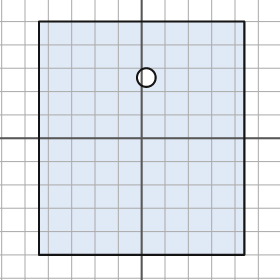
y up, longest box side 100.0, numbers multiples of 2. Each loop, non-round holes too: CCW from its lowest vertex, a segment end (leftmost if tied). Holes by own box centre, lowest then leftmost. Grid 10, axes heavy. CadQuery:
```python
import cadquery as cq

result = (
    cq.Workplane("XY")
    .moveTo(-44.0, -50.0)
    .lineTo(44.0, -50.0)
    .lineTo(44.0, 50.0)
    .lineTo(-44.0, 50.0)
    .close()
    .moveTo(2.0, 26.0)
    .circle(4.0)
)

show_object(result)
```